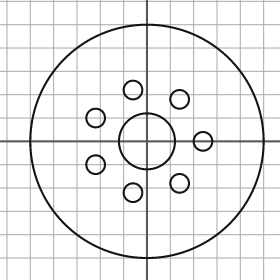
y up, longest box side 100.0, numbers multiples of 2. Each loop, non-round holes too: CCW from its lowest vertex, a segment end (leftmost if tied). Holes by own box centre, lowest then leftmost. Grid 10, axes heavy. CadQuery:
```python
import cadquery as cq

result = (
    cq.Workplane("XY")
    .moveTo(0.0, 0.0)
    .circle(50.0)
    .moveTo(-6.0, -22.0)
    .circle(4.0)
    .moveTo(14.0, -18.0)
    .circle(4.0)
    .moveTo(-22.0, -10.0)
    .circle(4.0)
    .moveTo(0.0, 0.0)
    .circle(12.0)
    .moveTo(24.0, 0.0)
    .circle(4.0)
    .moveTo(-22.0, 10.0)
    .circle(4.0)
    .moveTo(14.0, 18.0)
    .circle(4.0)
    .moveTo(-6.0, 22.0)
    .circle(4.0)
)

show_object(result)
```